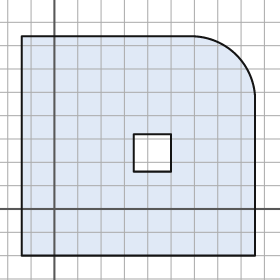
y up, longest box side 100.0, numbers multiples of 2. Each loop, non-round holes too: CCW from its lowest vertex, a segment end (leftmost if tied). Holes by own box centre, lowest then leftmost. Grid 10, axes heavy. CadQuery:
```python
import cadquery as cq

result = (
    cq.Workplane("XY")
    .moveTo(-14.0, -20.0)
    .lineTo(86.0, -20.0)
    .lineTo(86.0, 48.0)
    .threePointArc((78.0, 66.0), (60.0, 74.0))
    .lineTo(-14.0, 74.0)
    .close()
    .moveTo(34.0, 16.0)
    .lineTo(50.0, 16.0)
    .lineTo(50.0, 32.0)
    .lineTo(34.0, 32.0)
    .close()
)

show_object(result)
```